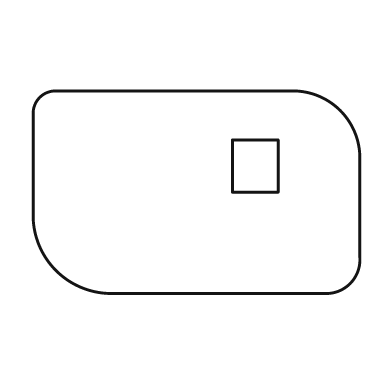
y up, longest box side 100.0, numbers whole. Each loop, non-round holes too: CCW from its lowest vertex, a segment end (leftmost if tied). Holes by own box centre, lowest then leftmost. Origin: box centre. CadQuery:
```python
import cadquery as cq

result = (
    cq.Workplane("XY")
    .moveTo(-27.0, -31.0)
    .lineTo(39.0, -31.0)
    .threePointArc((47.0, -28.0), (50.0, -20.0))
    .lineTo(50.0, 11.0)
    .threePointArc((44.0, 25.0), (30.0, 31.0))
    .lineTo(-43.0, 31.0)
    .threePointArc((-48.0, 29.0), (-50.0, 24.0))
    .lineTo(-50.0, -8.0)
    .threePointArc((-43.0, -24.0), (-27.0, -31.0))
    .close()
    .moveTo(11.0, 0.0)
    .lineTo(25.0, 0.0)
    .lineTo(25.0, 16.0)
    .lineTo(11.0, 16.0)
    .close()
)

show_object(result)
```